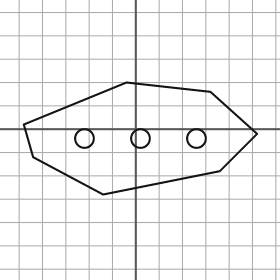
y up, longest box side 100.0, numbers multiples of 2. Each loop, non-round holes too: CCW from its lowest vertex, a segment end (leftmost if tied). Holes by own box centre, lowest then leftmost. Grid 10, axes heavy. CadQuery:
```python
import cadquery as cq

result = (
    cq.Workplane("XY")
    .moveTo(-14.0, -28.0)
    .lineTo(36.0, -18.0)
    .lineTo(52.0, -2.0)
    .lineTo(32.0, 16.0)
    .lineTo(-4.0, 20.0)
    .lineTo(-48.0, 2.0)
    .lineTo(-44.0, -12.0)
    .close()
    .moveTo(-22.0, -4.0)
    .circle(4.0)
    .moveTo(2.0, -4.0)
    .circle(4.0)
    .moveTo(26.0, -4.0)
    .circle(4.0)
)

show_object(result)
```